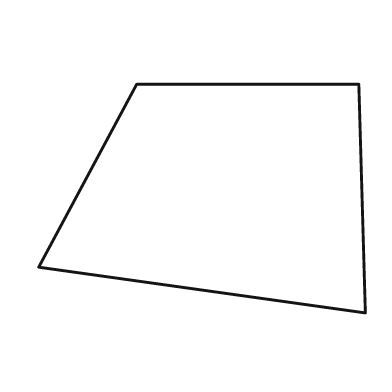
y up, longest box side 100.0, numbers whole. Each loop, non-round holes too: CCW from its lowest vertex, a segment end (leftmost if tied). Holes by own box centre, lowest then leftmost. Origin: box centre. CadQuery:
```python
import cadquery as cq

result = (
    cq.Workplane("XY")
    .moveTo(50.0, -35.0)
    .lineTo(48.0, 35.0)
    .lineTo(-20.0, 35.0)
    .lineTo(-50.0, -21.0)
    .close()
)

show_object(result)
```